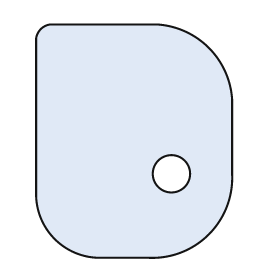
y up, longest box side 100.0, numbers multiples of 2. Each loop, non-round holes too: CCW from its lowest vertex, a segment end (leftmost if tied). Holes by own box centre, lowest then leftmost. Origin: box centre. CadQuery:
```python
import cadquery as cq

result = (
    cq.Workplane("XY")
    .moveTo(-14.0, -50.0)
    .lineTo(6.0, -50.0)
    .threePointArc((32.0, -40.0), (42.0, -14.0))
    .lineTo(42.0, 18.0)
    .threePointArc((32.0, 40.0), (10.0, 50.0))
    .lineTo(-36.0, 50.0)
    .threePointArc((-40.0, 48.0), (-42.0, 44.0))
    .lineTo(-42.0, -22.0)
    .threePointArc((-34.0, -42.0), (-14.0, -50.0))
    .close()
    .moveTo(16.0, -14.0)
    .circle(8.0)
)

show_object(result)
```